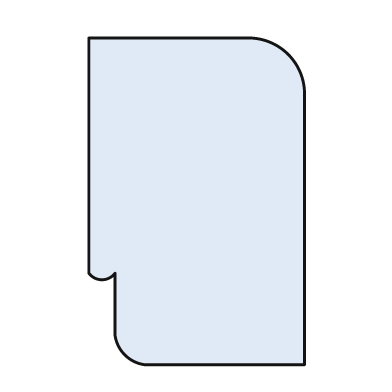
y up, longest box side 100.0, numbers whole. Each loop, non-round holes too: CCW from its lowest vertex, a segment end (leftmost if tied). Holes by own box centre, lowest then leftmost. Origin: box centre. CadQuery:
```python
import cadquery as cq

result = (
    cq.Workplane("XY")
    .moveTo(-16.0, -50.0)
    .lineTo(33.0, -50.0)
    .lineTo(33.0, 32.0)
    .threePointArc((28.0, 45.0), (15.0, 50.0))
    .lineTo(-33.0, 50.0)
    .lineTo(-33.0, -22.0)
    .threePointArc((-29.0, -24.0), (-25.0, -22.0))
    .lineTo(-25.0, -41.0)
    .threePointArc((-22.0, -47.0), (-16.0, -50.0))
    .close()
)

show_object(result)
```